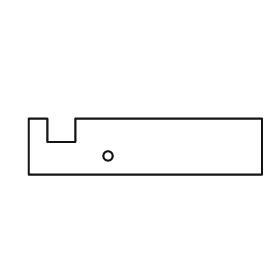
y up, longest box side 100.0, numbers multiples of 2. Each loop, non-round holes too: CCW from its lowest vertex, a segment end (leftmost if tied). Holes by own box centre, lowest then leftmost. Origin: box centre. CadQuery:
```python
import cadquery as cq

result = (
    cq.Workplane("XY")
    .moveTo(-50.0, -12.0)
    .lineTo(50.0, -12.0)
    .lineTo(50.0, 12.0)
    .lineTo(-30.0, 12.0)
    .lineTo(-30.0, 2.0)
    .lineTo(-42.0, 2.0)
    .lineTo(-42.0, 12.0)
    .lineTo(-50.0, 12.0)
    .close()
    .moveTo(-16.0, -4.0)
    .circle(2.0)
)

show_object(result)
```